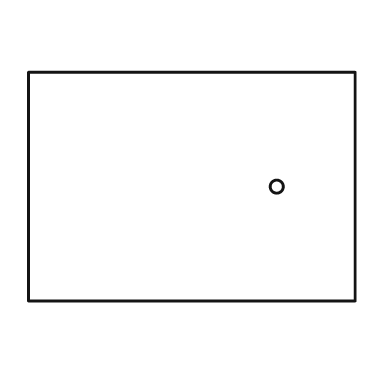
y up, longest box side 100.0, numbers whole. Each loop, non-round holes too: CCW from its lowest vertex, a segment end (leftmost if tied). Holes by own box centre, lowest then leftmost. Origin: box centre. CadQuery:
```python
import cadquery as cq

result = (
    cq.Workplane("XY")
    .moveTo(-50.0, -35.0)
    .lineTo(50.0, -35.0)
    .lineTo(50.0, 35.0)
    .lineTo(-50.0, 35.0)
    .close()
    .moveTo(26.0, 0.0)
    .circle(2.0)
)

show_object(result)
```